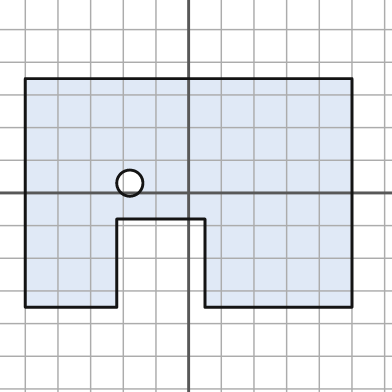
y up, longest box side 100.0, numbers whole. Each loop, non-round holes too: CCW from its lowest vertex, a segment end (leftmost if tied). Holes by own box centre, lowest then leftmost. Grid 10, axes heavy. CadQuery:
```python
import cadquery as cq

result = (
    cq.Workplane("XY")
    .moveTo(-50.0, -35.0)
    .lineTo(-22.0, -35.0)
    .lineTo(-22.0, -8.0)
    .lineTo(5.0, -8.0)
    .lineTo(5.0, -35.0)
    .lineTo(50.0, -35.0)
    .lineTo(50.0, 35.0)
    .lineTo(-50.0, 35.0)
    .close()
    .moveTo(-18.0, 3.0)
    .circle(4.0)
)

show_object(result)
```